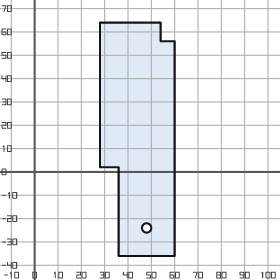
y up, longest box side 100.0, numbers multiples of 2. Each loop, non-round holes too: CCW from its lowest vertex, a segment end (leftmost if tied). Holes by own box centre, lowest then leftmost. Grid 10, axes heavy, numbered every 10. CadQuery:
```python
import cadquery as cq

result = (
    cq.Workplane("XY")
    .moveTo(36.0, -36.0)
    .lineTo(60.0, -36.0)
    .lineTo(60.0, 56.0)
    .lineTo(54.0, 56.0)
    .lineTo(54.0, 64.0)
    .lineTo(28.0, 64.0)
    .lineTo(28.0, 2.0)
    .lineTo(36.0, 2.0)
    .close()
    .moveTo(48.0, -24.0)
    .circle(2.0)
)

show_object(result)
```